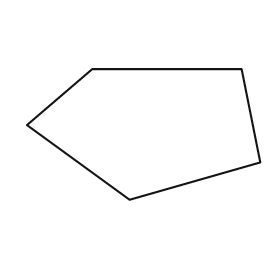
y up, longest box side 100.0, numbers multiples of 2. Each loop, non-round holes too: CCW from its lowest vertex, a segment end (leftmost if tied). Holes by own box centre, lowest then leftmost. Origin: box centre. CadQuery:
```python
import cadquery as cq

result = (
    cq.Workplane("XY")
    .moveTo(-6.0, -28.0)
    .lineTo(50.0, -12.0)
    .lineTo(42.0, 28.0)
    .lineTo(-22.0, 28.0)
    .lineTo(-50.0, 4.0)
    .close()
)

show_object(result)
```